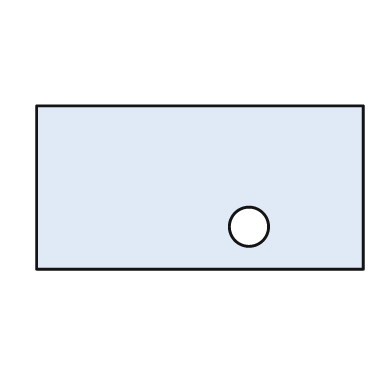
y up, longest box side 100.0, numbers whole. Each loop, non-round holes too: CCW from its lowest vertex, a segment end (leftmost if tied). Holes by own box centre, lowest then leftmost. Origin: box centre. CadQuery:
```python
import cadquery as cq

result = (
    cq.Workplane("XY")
    .moveTo(-50.0, -25.0)
    .lineTo(50.0, -25.0)
    .lineTo(50.0, 25.0)
    .lineTo(-50.0, 25.0)
    .close()
    .moveTo(15.0, -12.0)
    .circle(6.0)
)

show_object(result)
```